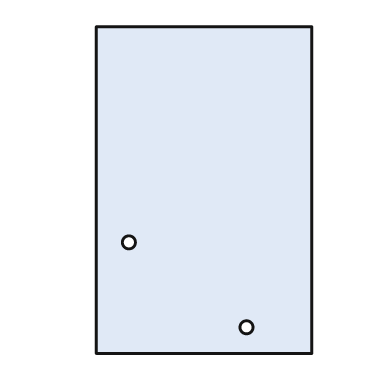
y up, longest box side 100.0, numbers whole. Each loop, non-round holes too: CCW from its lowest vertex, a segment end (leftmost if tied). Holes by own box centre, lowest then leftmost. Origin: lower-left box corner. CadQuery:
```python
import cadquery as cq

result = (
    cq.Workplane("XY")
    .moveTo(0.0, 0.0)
    .lineTo(66.0, 0.0)
    .lineTo(66.0, 100.0)
    .lineTo(0.0, 100.0)
    .close()
    .moveTo(46.0, 8.0)
    .circle(2.0)
    .moveTo(10.0, 34.0)
    .circle(2.0)
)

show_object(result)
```